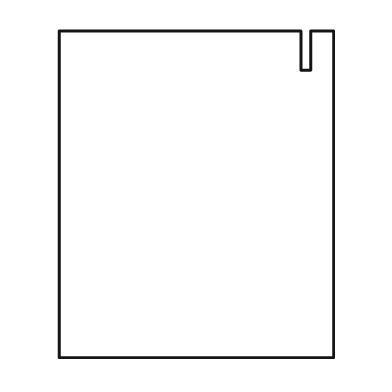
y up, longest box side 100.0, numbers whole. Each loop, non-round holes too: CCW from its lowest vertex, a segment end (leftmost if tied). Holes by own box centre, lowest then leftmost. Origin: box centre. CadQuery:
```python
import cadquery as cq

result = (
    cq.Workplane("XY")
    .moveTo(-42.0, -50.0)
    .lineTo(42.0, -50.0)
    .lineTo(42.0, 50.0)
    .lineTo(35.0, 50.0)
    .lineTo(35.0, 38.0)
    .lineTo(32.0, 38.0)
    .lineTo(32.0, 50.0)
    .lineTo(-42.0, 50.0)
    .close()
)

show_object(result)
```